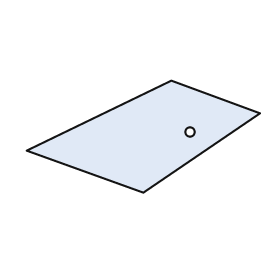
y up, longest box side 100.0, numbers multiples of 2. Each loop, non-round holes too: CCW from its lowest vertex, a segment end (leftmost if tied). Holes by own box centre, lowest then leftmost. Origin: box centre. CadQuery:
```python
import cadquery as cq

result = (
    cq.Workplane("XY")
    .moveTo(0.0, -24.0)
    .lineTo(50.0, 10.0)
    .lineTo(12.0, 24.0)
    .lineTo(-50.0, -6.0)
    .close()
    .moveTo(20.0, 2.0)
    .circle(2.0)
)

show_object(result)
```